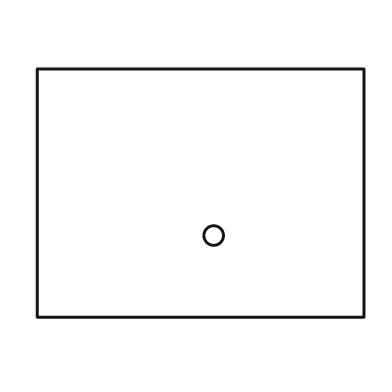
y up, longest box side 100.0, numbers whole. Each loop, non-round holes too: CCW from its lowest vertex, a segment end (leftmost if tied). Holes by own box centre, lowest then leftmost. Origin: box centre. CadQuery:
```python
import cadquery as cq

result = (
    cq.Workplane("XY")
    .moveTo(-50.0, -38.0)
    .lineTo(50.0, -38.0)
    .lineTo(50.0, 38.0)
    .lineTo(-50.0, 38.0)
    .close()
    .moveTo(4.0, -13.0)
    .circle(3.0)
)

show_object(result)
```